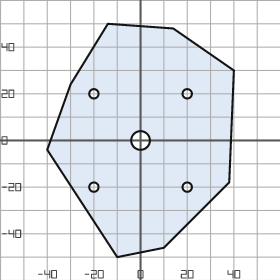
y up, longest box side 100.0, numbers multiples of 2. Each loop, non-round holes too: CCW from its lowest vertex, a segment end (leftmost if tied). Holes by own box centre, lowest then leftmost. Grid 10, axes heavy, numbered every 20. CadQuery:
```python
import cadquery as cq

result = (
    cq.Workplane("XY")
    .moveTo(-10.0, -50.0)
    .lineTo(10.0, -46.0)
    .lineTo(38.0, -18.0)
    .lineTo(40.0, 30.0)
    .lineTo(14.0, 48.0)
    .lineTo(-14.0, 50.0)
    .lineTo(-30.0, 24.0)
    .lineTo(-40.0, -4.0)
    .close()
    .moveTo(-20.0, -20.0)
    .circle(2.0)
    .moveTo(20.0, -20.0)
    .circle(2.0)
    .moveTo(0.0, 0.0)
    .circle(4.0)
    .moveTo(-20.0, 20.0)
    .circle(2.0)
    .moveTo(20.0, 20.0)
    .circle(2.0)
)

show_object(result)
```